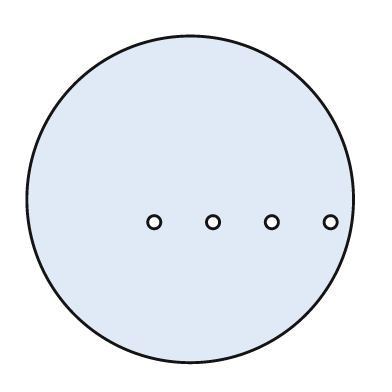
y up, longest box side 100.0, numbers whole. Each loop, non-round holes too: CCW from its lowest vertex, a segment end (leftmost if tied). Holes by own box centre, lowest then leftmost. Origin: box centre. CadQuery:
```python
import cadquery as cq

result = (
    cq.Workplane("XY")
    .moveTo(0.0, 0.0)
    .circle(50.0)
    .moveTo(-11.0, -7.0)
    .circle(2.0)
    .moveTo(7.0, -7.0)
    .circle(2.0)
    .moveTo(25.0, -7.0)
    .circle(2.0)
    .moveTo(43.0, -7.0)
    .circle(2.0)
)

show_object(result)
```